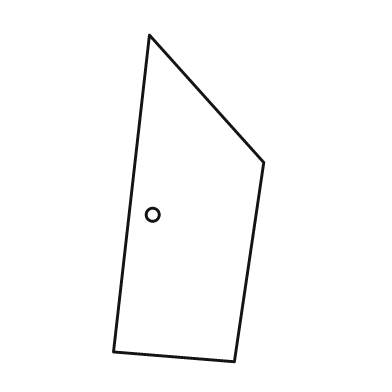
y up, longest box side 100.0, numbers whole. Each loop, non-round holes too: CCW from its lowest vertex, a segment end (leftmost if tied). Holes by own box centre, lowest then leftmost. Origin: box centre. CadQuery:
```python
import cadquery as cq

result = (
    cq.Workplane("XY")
    .moveTo(14.0, -50.0)
    .lineTo(23.0, 11.0)
    .lineTo(-12.0, 50.0)
    .lineTo(-23.0, -47.0)
    .close()
    .moveTo(-11.0, -5.0)
    .circle(2.0)
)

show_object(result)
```